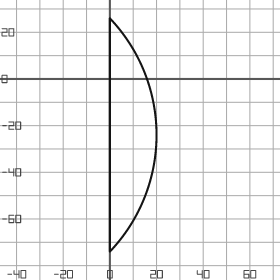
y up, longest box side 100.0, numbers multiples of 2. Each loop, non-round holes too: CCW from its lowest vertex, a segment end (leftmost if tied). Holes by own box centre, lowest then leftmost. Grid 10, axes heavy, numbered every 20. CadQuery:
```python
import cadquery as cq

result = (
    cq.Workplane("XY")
    .moveTo(0.0, -74.0)
    .threePointArc((20.0, -24.0), (0.0, 26.0))
    .close()
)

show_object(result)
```